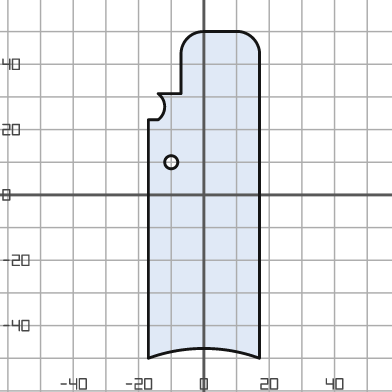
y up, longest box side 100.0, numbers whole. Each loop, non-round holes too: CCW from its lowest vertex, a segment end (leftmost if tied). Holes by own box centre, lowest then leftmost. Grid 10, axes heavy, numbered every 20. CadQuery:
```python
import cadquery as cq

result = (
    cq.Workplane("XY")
    .moveTo(-17.0, -50.0)
    .threePointArc((0.0, -47.0), (17.0, -50.0))
    .lineTo(17.0, 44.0)
    .threePointArc((15.0, 48.0), (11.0, 50.0))
    .lineTo(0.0, 50.0)
    .threePointArc((-5.0, 48.0), (-7.0, 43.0))
    .lineTo(-7.0, 31.0)
    .lineTo(-14.0, 31.0)
    .threePointArc((-12.0, 27.0), (-14.0, 23.0))
    .lineTo(-17.0, 23.0)
    .close()
    .moveTo(-10.0, 10.0)
    .circle(2.0)
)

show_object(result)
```